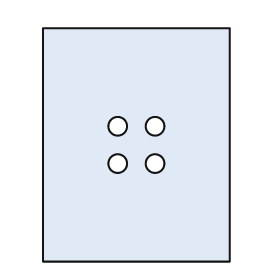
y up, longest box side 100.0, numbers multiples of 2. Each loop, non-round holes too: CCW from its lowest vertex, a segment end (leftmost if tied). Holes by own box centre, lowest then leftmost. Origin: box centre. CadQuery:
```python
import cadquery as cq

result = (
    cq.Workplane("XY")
    .moveTo(-40.0, -50.0)
    .lineTo(40.0, -50.0)
    .lineTo(40.0, 50.0)
    .lineTo(-40.0, 50.0)
    .close()
    .moveTo(-8.0, -8.0)
    .circle(4.0)
    .moveTo(8.0, -8.0)
    .circle(4.0)
    .moveTo(-8.0, 8.0)
    .circle(4.0)
    .moveTo(8.0, 8.0)
    .circle(4.0)
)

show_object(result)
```